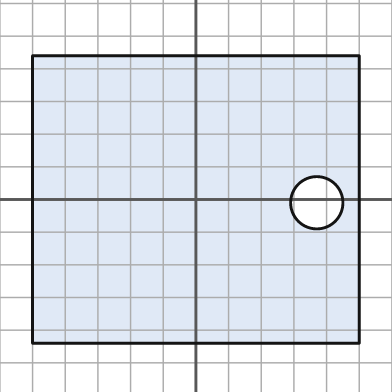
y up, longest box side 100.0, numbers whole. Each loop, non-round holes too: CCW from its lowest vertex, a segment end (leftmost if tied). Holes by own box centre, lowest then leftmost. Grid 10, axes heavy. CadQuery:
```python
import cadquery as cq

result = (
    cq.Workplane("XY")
    .moveTo(-50.0, -44.0)
    .lineTo(50.0, -44.0)
    .lineTo(50.0, 44.0)
    .lineTo(-50.0, 44.0)
    .close()
    .moveTo(37.0, -1.0)
    .circle(8.0)
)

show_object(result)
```